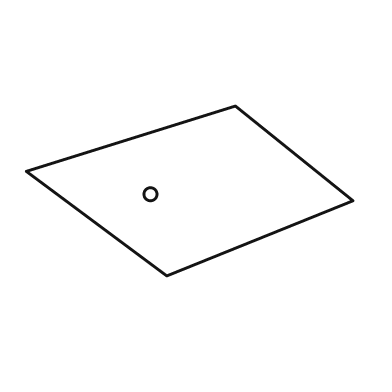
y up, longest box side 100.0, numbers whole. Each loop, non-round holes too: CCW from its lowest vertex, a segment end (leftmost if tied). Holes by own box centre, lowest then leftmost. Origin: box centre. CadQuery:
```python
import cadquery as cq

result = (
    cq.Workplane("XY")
    .moveTo(-7.0, -26.0)
    .lineTo(50.0, -3.0)
    .lineTo(14.0, 26.0)
    .lineTo(-50.0, 6.0)
    .close()
    .moveTo(-12.0, -1.0)
    .circle(2.0)
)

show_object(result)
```